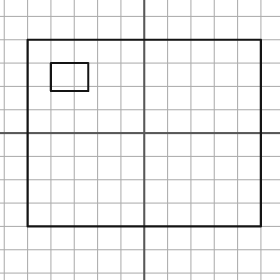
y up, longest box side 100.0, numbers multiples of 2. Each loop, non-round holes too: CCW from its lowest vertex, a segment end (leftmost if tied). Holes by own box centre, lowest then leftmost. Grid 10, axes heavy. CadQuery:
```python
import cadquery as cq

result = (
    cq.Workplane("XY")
    .moveTo(-50.0, -40.0)
    .lineTo(50.0, -40.0)
    .lineTo(50.0, 40.0)
    .lineTo(-50.0, 40.0)
    .close()
    .moveTo(-40.0, 18.0)
    .lineTo(-24.0, 18.0)
    .lineTo(-24.0, 30.0)
    .lineTo(-40.0, 30.0)
    .close()
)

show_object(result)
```